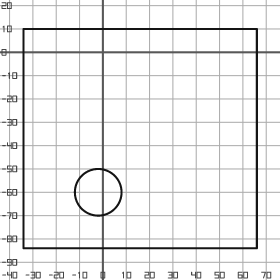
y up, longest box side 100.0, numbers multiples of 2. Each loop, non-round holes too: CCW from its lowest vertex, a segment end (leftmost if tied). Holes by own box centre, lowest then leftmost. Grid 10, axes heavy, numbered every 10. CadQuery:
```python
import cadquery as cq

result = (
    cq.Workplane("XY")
    .moveTo(-34.0, -84.0)
    .lineTo(66.0, -84.0)
    .lineTo(66.0, 10.0)
    .lineTo(-34.0, 10.0)
    .close()
    .moveTo(-2.0, -60.0)
    .circle(10.0)
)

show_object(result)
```